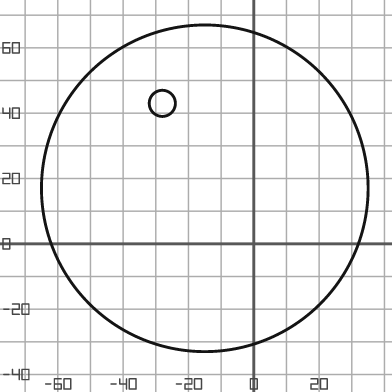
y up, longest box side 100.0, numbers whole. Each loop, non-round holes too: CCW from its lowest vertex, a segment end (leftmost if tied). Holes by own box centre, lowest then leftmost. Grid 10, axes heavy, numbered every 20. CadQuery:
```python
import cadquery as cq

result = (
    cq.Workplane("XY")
    .moveTo(-15.0, 17.0)
    .circle(50.0)
    .moveTo(-28.0, 43.0)
    .circle(4.0)
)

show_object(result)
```